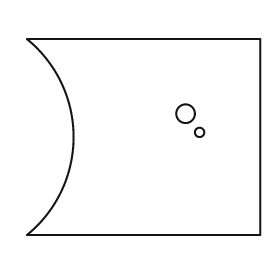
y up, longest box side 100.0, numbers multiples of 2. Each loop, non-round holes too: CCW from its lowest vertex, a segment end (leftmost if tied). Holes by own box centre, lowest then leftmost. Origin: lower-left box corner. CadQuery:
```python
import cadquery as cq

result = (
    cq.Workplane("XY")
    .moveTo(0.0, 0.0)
    .lineTo(100.0, 0.0)
    .lineTo(100.0, 84.0)
    .lineTo(0.0, 84.0)
    .threePointArc((20.0, 42.0), (0.0, 0.0))
    .close()
    .moveTo(74.0, 44.0)
    .circle(2.0)
    .moveTo(68.0, 52.0)
    .circle(4.0)
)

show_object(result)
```